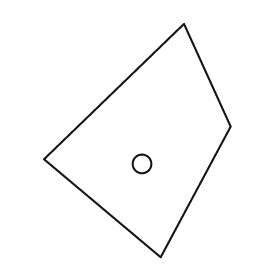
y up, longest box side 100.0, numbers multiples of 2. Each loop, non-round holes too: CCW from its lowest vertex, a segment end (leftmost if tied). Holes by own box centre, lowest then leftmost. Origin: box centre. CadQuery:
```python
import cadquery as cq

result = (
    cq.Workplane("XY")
    .moveTo(10.0, -50.0)
    .lineTo(40.0, 6.0)
    .lineTo(20.0, 50.0)
    .lineTo(-40.0, -8.0)
    .close()
    .moveTo(2.0, -10.0)
    .circle(4.0)
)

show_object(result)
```